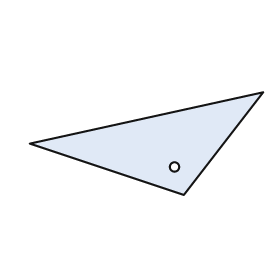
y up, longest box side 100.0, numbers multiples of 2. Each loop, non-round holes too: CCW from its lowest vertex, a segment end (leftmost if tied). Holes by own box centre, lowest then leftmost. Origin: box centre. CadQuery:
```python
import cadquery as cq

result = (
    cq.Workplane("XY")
    .moveTo(16.0, -22.0)
    .lineTo(50.0, 22.0)
    .lineTo(-50.0, 0.0)
    .close()
    .moveTo(12.0, -10.0)
    .circle(2.0)
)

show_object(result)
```